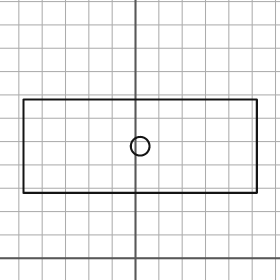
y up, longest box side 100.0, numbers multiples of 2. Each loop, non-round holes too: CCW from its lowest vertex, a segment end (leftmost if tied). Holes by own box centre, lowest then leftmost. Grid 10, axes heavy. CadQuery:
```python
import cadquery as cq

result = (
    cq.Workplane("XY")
    .moveTo(-48.0, 28.0)
    .lineTo(52.0, 28.0)
    .lineTo(52.0, 68.0)
    .lineTo(-48.0, 68.0)
    .close()
    .moveTo(2.0, 48.0)
    .circle(4.0)
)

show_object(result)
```